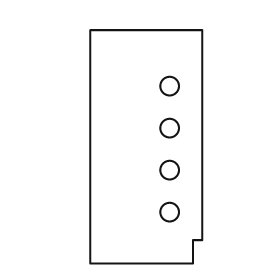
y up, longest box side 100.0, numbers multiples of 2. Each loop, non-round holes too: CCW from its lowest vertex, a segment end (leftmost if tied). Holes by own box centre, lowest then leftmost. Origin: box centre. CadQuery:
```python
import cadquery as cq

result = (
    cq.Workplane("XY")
    .moveTo(-24.0, -50.0)
    .lineTo(20.0, -50.0)
    .lineTo(20.0, -40.0)
    .lineTo(24.0, -40.0)
    .lineTo(24.0, 50.0)
    .lineTo(-24.0, 50.0)
    .close()
    .moveTo(10.0, -28.0)
    .circle(4.0)
    .moveTo(10.0, -10.0)
    .circle(4.0)
    .moveTo(10.0, 8.0)
    .circle(4.0)
    .moveTo(10.0, 26.0)
    .circle(4.0)
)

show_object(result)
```